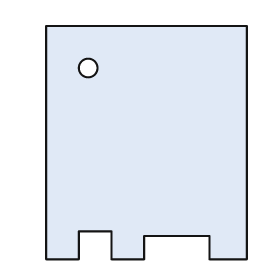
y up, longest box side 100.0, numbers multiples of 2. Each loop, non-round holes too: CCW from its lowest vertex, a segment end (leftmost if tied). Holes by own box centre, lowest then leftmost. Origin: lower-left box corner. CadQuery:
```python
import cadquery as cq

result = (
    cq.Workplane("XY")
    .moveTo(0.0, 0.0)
    .lineTo(14.0, 0.0)
    .lineTo(14.0, 12.0)
    .lineTo(28.0, 12.0)
    .lineTo(28.0, 0.0)
    .lineTo(42.0, 0.0)
    .lineTo(42.0, 10.0)
    .lineTo(70.0, 10.0)
    .lineTo(70.0, 0.0)
    .lineTo(86.0, 0.0)
    .lineTo(86.0, 100.0)
    .lineTo(0.0, 100.0)
    .close()
    .moveTo(18.0, 82.0)
    .circle(4.0)
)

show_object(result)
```